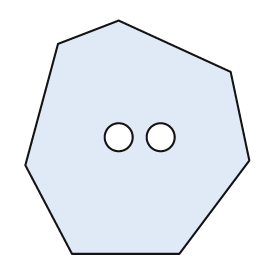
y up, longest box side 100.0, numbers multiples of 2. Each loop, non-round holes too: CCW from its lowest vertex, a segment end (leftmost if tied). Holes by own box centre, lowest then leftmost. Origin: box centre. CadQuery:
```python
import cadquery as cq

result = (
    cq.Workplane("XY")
    .moveTo(-28.0, -50.0)
    .lineTo(18.0, -50.0)
    .lineTo(48.0, -10.0)
    .lineTo(40.0, 28.0)
    .lineTo(-8.0, 50.0)
    .lineTo(-34.0, 40.0)
    .lineTo(-48.0, -12.0)
    .close()
    .moveTo(-8.0, 0.0)
    .circle(6.0)
    .moveTo(10.0, 0.0)
    .circle(6.0)
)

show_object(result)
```